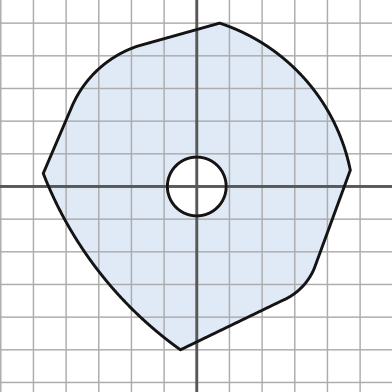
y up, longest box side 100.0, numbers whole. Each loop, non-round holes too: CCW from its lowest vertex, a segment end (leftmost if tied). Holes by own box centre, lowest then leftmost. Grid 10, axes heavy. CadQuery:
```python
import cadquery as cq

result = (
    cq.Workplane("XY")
    .moveTo(-5.0, -50.0)
    .lineTo(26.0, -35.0)
    .threePointArc((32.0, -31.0), (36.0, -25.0))
    .lineTo(47.0, 5.0)
    .threePointArc((33.0, 33.0), (7.0, 50.0))
    .lineTo(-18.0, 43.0)
    .threePointArc((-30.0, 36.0), (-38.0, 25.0))
    .lineTo(-47.0, 4.0)
    .threePointArc((-30.0, -26.0), (-5.0, -50.0))
    .close()
    .moveTo(0.0, 0.0)
    .circle(9.0)
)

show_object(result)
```